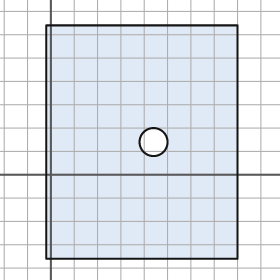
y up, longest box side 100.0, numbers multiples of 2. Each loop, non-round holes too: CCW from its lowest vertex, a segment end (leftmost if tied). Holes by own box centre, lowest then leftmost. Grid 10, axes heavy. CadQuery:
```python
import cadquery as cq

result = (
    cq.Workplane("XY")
    .moveTo(-2.0, -36.0)
    .lineTo(80.0, -36.0)
    .lineTo(80.0, 64.0)
    .lineTo(-2.0, 64.0)
    .close()
    .moveTo(44.0, 14.0)
    .circle(6.0)
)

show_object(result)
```